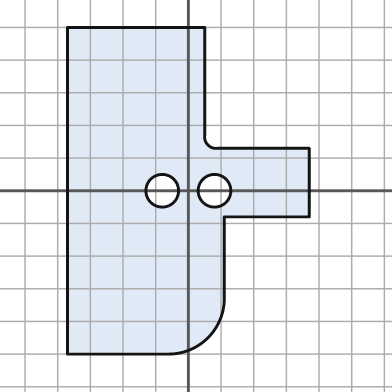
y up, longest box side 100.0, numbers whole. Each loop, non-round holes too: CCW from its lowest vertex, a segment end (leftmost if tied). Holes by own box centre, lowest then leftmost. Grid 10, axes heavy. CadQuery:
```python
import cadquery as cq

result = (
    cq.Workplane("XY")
    .moveTo(-37.0, -50.0)
    .lineTo(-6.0, -50.0)
    .threePointArc((6.0, -45.0), (11.0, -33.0))
    .lineTo(11.0, -8.0)
    .lineTo(37.0, -8.0)
    .lineTo(37.0, 13.0)
    .lineTo(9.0, 13.0)
    .threePointArc((6.0, 14.0), (5.0, 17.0))
    .lineTo(5.0, 50.0)
    .lineTo(-37.0, 50.0)
    .close()
    .moveTo(-8.0, 0.0)
    .circle(5.0)
    .moveTo(8.0, 0.0)
    .circle(5.0)
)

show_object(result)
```